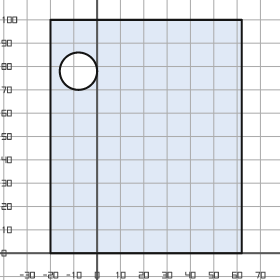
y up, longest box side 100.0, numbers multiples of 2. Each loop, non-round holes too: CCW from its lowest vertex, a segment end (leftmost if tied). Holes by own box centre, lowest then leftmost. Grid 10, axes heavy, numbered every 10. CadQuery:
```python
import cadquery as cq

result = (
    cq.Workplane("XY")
    .moveTo(-20.0, 0.0)
    .lineTo(62.0, 0.0)
    .lineTo(62.0, 100.0)
    .lineTo(-20.0, 100.0)
    .close()
    .moveTo(-8.0, 78.0)
    .circle(8.0)
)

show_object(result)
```